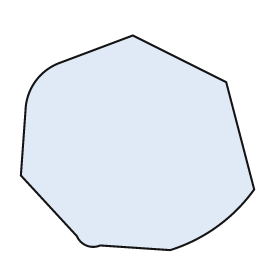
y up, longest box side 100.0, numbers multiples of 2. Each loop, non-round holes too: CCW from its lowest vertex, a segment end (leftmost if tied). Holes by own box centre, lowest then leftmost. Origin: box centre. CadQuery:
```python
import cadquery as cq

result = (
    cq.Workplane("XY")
    .moveTo(14.0, -46.0)
    .threePointArc((34.0, -36.0), (50.0, -20.0))
    .lineTo(38.0, 26.0)
    .lineTo(-2.0, 46.0)
    .lineTo(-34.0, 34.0)
    .threePointArc((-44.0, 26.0), (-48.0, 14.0))
    .lineTo(-50.0, -14.0)
    .lineTo(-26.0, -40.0)
    .threePointArc((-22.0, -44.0), (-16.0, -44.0))
    .close()
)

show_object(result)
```